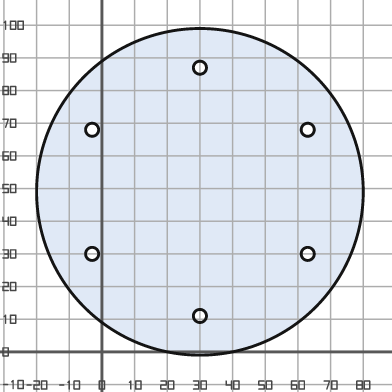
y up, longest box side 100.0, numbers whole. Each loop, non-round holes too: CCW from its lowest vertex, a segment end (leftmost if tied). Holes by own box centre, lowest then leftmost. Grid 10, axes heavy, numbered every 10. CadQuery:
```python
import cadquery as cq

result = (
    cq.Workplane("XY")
    .moveTo(30.0, 49.0)
    .circle(50.0)
    .moveTo(30.0, 11.0)
    .circle(2.0)
    .moveTo(-3.0, 30.0)
    .circle(2.0)
    .moveTo(63.0, 30.0)
    .circle(2.0)
    .moveTo(-3.0, 68.0)
    .circle(2.0)
    .moveTo(63.0, 68.0)
    .circle(2.0)
    .moveTo(30.0, 87.0)
    .circle(2.0)
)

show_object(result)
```